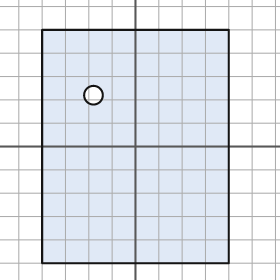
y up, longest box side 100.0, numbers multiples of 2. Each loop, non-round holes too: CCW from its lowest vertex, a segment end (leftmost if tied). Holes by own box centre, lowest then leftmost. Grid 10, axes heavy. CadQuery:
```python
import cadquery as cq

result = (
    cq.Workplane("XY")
    .moveTo(-40.0, -50.0)
    .lineTo(40.0, -50.0)
    .lineTo(40.0, 50.0)
    .lineTo(-40.0, 50.0)
    .close()
    .moveTo(-18.0, 22.0)
    .circle(4.0)
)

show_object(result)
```